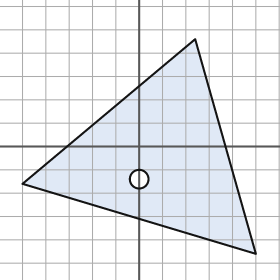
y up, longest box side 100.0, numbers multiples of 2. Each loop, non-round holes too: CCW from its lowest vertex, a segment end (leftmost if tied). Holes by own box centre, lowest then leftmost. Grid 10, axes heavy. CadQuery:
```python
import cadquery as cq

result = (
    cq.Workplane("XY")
    .moveTo(50.0, -46.0)
    .lineTo(24.0, 46.0)
    .lineTo(-50.0, -16.0)
    .close()
    .moveTo(0.0, -14.0)
    .circle(4.0)
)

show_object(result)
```